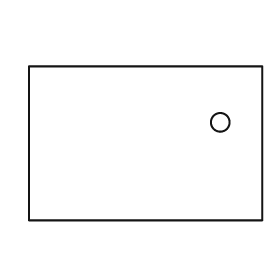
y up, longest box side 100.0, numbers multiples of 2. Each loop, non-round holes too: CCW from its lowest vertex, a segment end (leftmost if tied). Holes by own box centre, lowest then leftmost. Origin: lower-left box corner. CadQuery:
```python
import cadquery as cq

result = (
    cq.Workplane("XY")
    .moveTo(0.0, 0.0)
    .lineTo(100.0, 0.0)
    .lineTo(100.0, 66.0)
    .lineTo(0.0, 66.0)
    .close()
    .moveTo(82.0, 42.0)
    .circle(4.0)
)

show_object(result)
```